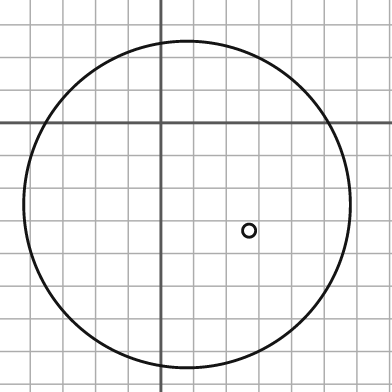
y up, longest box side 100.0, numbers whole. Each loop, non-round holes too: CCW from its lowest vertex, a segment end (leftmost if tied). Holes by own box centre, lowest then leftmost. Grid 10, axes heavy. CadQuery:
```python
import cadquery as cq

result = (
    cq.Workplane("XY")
    .moveTo(8.0, -25.0)
    .circle(50.0)
    .moveTo(27.0, -33.0)
    .circle(2.0)
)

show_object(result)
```